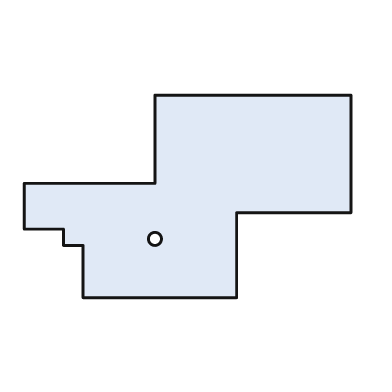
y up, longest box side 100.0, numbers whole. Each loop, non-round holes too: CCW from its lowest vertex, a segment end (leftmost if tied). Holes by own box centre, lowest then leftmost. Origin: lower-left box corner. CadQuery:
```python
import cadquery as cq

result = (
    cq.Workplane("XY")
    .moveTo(18.0, 0.0)
    .lineTo(65.0, 0.0)
    .lineTo(65.0, 26.0)
    .lineTo(100.0, 26.0)
    .lineTo(100.0, 62.0)
    .lineTo(40.0, 62.0)
    .lineTo(40.0, 35.0)
    .lineTo(0.0, 35.0)
    .lineTo(0.0, 21.0)
    .lineTo(12.0, 21.0)
    .lineTo(12.0, 16.0)
    .lineTo(18.0, 16.0)
    .close()
    .moveTo(40.0, 18.0)
    .circle(2.0)
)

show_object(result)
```